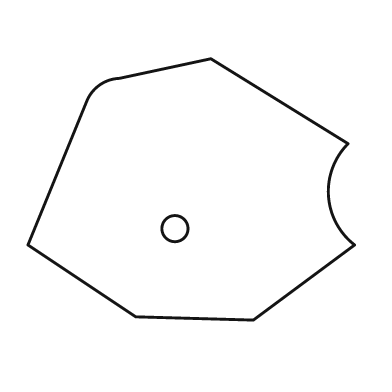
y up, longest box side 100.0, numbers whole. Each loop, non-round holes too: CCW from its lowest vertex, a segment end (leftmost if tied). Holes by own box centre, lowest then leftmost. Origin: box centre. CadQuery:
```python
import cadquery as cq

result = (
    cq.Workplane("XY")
    .moveTo(19.0, -40.0)
    .lineTo(50.0, -17.0)
    .threePointArc((42.0, -2.0), (48.0, 14.0))
    .lineTo(6.0, 40.0)
    .lineTo(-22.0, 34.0)
    .threePointArc((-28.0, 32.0), (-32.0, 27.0))
    .lineTo(-50.0, -17.0)
    .lineTo(-17.0, -39.0)
    .close()
    .moveTo(-5.0, -12.0)
    .circle(4.0)
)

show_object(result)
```